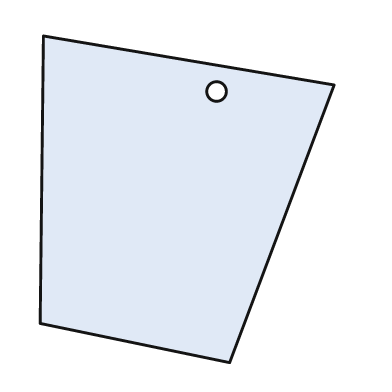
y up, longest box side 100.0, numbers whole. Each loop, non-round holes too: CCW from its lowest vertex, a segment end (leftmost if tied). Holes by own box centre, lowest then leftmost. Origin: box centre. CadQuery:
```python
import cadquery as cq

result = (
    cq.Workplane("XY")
    .moveTo(13.0, -50.0)
    .lineTo(45.0, 35.0)
    .lineTo(-44.0, 50.0)
    .lineTo(-45.0, -38.0)
    .close()
    .moveTo(9.0, 33.0)
    .circle(3.0)
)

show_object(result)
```